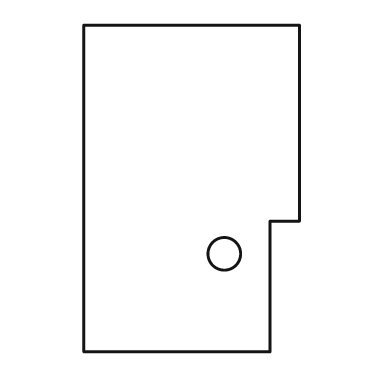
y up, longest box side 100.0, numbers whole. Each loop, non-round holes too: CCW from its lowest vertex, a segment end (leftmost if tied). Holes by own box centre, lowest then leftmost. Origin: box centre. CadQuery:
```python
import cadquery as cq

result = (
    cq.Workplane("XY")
    .moveTo(-33.0, -50.0)
    .lineTo(24.0, -50.0)
    .lineTo(24.0, -10.0)
    .lineTo(33.0, -10.0)
    .lineTo(33.0, 50.0)
    .lineTo(-33.0, 50.0)
    .close()
    .moveTo(10.0, -20.0)
    .circle(5.0)
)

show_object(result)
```